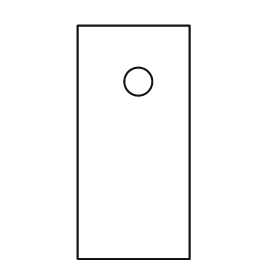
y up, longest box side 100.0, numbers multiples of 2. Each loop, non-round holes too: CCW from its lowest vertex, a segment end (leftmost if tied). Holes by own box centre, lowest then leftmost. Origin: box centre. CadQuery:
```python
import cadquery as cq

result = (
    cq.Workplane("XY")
    .moveTo(-24.0, -50.0)
    .lineTo(24.0, -50.0)
    .lineTo(24.0, 50.0)
    .lineTo(-24.0, 50.0)
    .close()
    .moveTo(2.0, 26.0)
    .circle(6.0)
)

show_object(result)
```